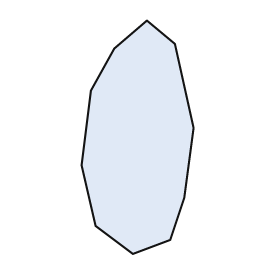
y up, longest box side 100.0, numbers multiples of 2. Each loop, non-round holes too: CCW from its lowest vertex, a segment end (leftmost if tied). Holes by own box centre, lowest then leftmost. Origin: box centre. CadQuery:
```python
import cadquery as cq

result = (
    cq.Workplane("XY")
    .moveTo(-2.0, -50.0)
    .lineTo(14.0, -44.0)
    .lineTo(20.0, -26.0)
    .lineTo(24.0, 4.0)
    .lineTo(16.0, 40.0)
    .lineTo(4.0, 50.0)
    .lineTo(-10.0, 38.0)
    .lineTo(-20.0, 20.0)
    .lineTo(-24.0, -12.0)
    .lineTo(-18.0, -38.0)
    .close()
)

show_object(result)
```